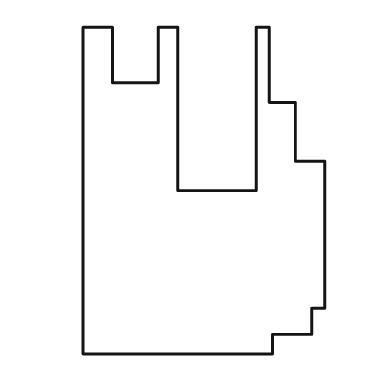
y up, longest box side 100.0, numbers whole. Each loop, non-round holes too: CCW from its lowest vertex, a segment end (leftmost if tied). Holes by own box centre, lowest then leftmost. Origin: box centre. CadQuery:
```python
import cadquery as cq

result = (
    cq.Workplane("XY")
    .moveTo(-37.0, -50.0)
    .lineTo(21.0, -50.0)
    .lineTo(21.0, -44.0)
    .lineTo(33.0, -44.0)
    .lineTo(33.0, -36.0)
    .lineTo(37.0, -36.0)
    .lineTo(37.0, 9.0)
    .lineTo(28.0, 9.0)
    .lineTo(28.0, 27.0)
    .lineTo(20.0, 27.0)
    .lineTo(20.0, 50.0)
    .lineTo(16.0, 50.0)
    .lineTo(16.0, 0.0)
    .lineTo(-8.0, 0.0)
    .lineTo(-8.0, 50.0)
    .lineTo(-14.0, 50.0)
    .lineTo(-14.0, 33.0)
    .lineTo(-28.0, 33.0)
    .lineTo(-28.0, 50.0)
    .lineTo(-37.0, 50.0)
    .close()
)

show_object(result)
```